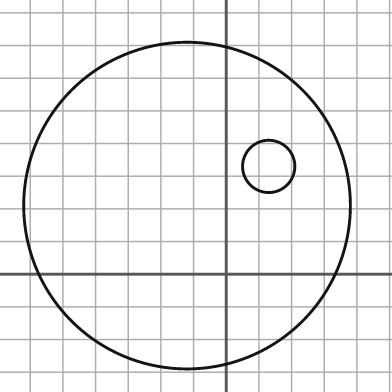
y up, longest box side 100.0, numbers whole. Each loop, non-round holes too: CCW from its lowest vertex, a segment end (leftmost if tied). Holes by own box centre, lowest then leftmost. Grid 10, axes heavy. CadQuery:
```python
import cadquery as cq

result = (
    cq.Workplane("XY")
    .moveTo(-12.0, 21.0)
    .circle(50.0)
    .moveTo(13.0, 33.0)
    .circle(8.0)
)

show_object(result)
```